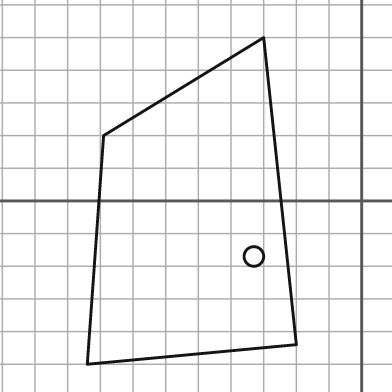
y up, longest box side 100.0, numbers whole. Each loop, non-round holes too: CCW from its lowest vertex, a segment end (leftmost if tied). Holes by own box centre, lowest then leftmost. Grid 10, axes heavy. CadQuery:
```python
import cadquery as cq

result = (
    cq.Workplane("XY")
    .moveTo(-84.0, -50.0)
    .lineTo(-20.0, -44.0)
    .lineTo(-30.0, 50.0)
    .lineTo(-79.0, 20.0)
    .close()
    .moveTo(-33.0, -17.0)
    .circle(3.0)
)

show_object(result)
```